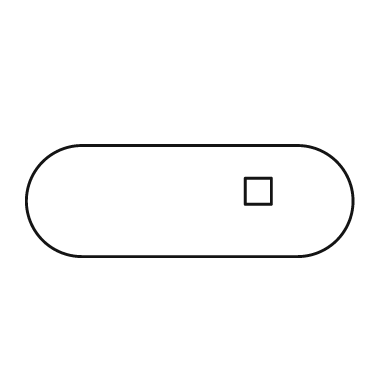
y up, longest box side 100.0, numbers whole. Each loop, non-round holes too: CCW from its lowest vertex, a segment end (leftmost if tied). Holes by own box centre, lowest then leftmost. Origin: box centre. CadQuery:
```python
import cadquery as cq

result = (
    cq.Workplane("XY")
    .moveTo(-33.0, -17.0)
    .lineTo(33.0, -17.0)
    .threePointArc((50.0, 0.0), (33.0, 17.0))
    .lineTo(-33.0, 17.0)
    .threePointArc((-50.0, 0.0), (-33.0, -17.0))
    .close()
    .moveTo(17.0, -1.0)
    .lineTo(25.0, -1.0)
    .lineTo(25.0, 7.0)
    .lineTo(17.0, 7.0)
    .close()
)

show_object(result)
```